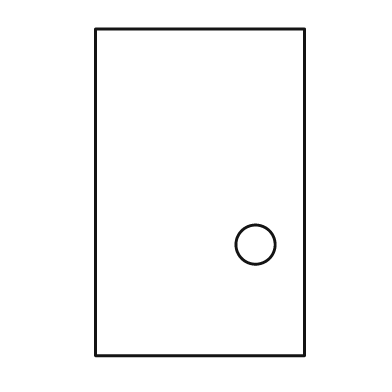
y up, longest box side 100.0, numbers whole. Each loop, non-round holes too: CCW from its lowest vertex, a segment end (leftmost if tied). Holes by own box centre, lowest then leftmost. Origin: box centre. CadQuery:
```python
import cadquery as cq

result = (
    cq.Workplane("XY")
    .moveTo(-32.0, -50.0)
    .lineTo(32.0, -50.0)
    .lineTo(32.0, 50.0)
    .lineTo(-32.0, 50.0)
    .close()
    .moveTo(17.0, -16.0)
    .circle(6.0)
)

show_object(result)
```